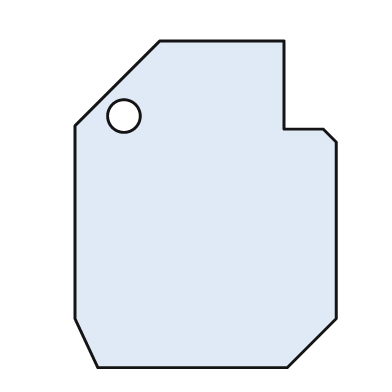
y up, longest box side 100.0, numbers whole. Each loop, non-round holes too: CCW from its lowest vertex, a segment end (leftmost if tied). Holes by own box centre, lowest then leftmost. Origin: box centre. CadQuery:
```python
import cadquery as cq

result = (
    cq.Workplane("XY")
    .moveTo(-33.0, -50.0)
    .lineTo(25.0, -50.0)
    .lineTo(40.0, -35.0)
    .lineTo(40.0, 19.0)
    .lineTo(36.0, 23.0)
    .lineTo(24.0, 23.0)
    .lineTo(24.0, 50.0)
    .lineTo(-14.0, 50.0)
    .lineTo(-40.0, 24.0)
    .lineTo(-40.0, -35.0)
    .close()
    .moveTo(-25.0, 27.0)
    .circle(5.0)
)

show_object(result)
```